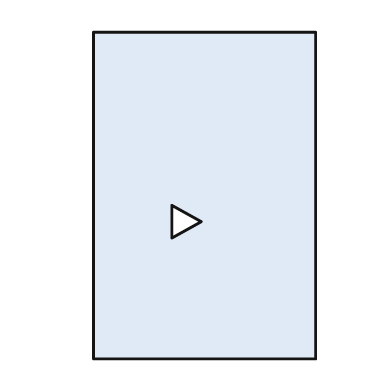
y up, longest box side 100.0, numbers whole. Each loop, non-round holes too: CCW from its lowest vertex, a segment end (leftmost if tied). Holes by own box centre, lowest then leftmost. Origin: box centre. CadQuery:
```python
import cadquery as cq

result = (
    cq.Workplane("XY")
    .moveTo(-34.0, -50.0)
    .lineTo(34.0, -50.0)
    .lineTo(34.0, 50.0)
    .lineTo(-34.0, 50.0)
    .close()
    .moveTo(-10.0, -13.0)
    .lineTo(-1.0, -8.0)
    .lineTo(-10.0, -3.0)
    .close()
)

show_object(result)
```